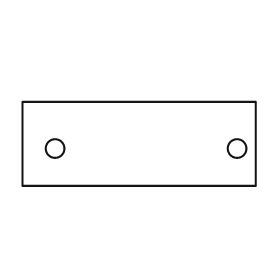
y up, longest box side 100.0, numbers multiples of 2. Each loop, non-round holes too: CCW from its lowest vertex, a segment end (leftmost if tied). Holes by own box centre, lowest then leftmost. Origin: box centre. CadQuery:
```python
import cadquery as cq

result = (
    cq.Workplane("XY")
    .moveTo(-50.0, -18.0)
    .lineTo(50.0, -18.0)
    .lineTo(50.0, 18.0)
    .lineTo(-50.0, 18.0)
    .close()
    .moveTo(-36.0, -2.0)
    .circle(4.0)
    .moveTo(42.0, -2.0)
    .circle(4.0)
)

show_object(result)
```